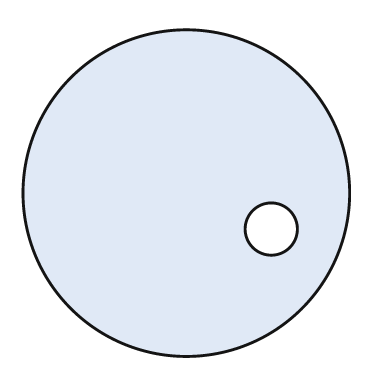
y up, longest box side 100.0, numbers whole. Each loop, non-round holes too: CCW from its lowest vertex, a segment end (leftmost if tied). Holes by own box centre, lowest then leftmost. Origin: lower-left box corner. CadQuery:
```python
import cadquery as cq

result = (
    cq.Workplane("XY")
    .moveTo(50.0, 50.0)
    .circle(50.0)
    .moveTo(76.0, 39.0)
    .circle(8.0)
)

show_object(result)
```